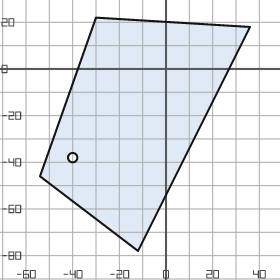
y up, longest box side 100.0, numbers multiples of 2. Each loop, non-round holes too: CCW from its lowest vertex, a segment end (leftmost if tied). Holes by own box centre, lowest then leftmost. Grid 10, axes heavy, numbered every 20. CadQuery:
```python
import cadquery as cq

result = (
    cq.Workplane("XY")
    .moveTo(-12.0, -78.0)
    .lineTo(36.0, 18.0)
    .lineTo(-30.0, 22.0)
    .lineTo(-54.0, -46.0)
    .close()
    .moveTo(-40.0, -38.0)
    .circle(2.0)
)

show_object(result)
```